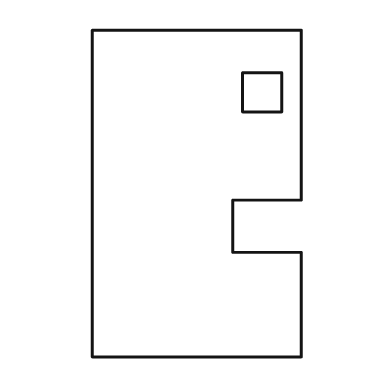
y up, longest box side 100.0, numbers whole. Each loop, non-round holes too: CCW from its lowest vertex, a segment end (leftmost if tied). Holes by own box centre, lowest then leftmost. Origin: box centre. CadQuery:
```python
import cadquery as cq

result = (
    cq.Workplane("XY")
    .moveTo(-32.0, -50.0)
    .lineTo(32.0, -50.0)
    .lineTo(32.0, -18.0)
    .lineTo(11.0, -18.0)
    .lineTo(11.0, -2.0)
    .lineTo(32.0, -2.0)
    .lineTo(32.0, 50.0)
    .lineTo(-32.0, 50.0)
    .close()
    .moveTo(14.0, 25.0)
    .lineTo(26.0, 25.0)
    .lineTo(26.0, 37.0)
    .lineTo(14.0, 37.0)
    .close()
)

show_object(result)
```